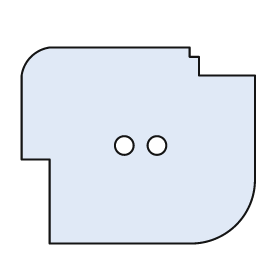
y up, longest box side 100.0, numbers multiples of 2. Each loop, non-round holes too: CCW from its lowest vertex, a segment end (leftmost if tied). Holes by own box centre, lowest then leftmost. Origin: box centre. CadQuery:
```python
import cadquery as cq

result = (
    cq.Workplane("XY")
    .moveTo(-38.0, -42.0)
    .lineTo(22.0, -42.0)
    .threePointArc((42.0, -34.0), (50.0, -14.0))
    .lineTo(50.0, 30.0)
    .lineTo(26.0, 30.0)
    .lineTo(26.0, 38.0)
    .lineTo(22.0, 38.0)
    .lineTo(22.0, 42.0)
    .lineTo(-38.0, 42.0)
    .threePointArc((-46.0, 38.0), (-50.0, 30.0))
    .lineTo(-50.0, -6.0)
    .lineTo(-38.0, -6.0)
    .close()
    .moveTo(-6.0, 0.0)
    .circle(4.0)
    .moveTo(8.0, 0.0)
    .circle(4.0)
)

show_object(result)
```